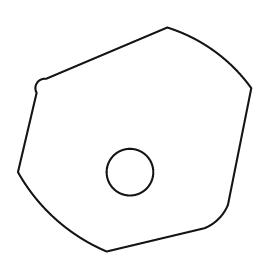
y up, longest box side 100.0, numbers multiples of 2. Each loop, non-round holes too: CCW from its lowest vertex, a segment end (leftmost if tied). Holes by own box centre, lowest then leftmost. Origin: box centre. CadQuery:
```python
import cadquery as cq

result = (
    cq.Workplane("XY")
    .moveTo(-12.0, -48.0)
    .lineTo(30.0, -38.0)
    .threePointArc((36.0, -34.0), (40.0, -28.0))
    .lineTo(50.0, 22.0)
    .threePointArc((34.0, 38.0), (14.0, 48.0))
    .lineTo(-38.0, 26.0)
    .threePointArc((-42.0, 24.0), (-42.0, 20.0))
    .lineTo(-50.0, -14.0)
    .threePointArc((-34.0, -34.0), (-12.0, -48.0))
    .close()
    .moveTo(-2.0, -14.0)
    .circle(10.0)
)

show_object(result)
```